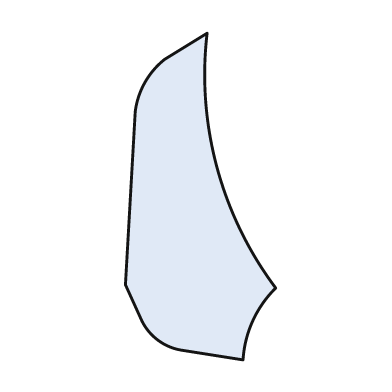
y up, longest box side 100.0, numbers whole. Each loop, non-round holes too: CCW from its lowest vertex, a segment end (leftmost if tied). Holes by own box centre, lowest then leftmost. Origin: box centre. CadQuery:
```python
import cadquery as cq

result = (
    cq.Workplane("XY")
    .moveTo(13.0, -50.0)
    .threePointArc((16.0, -38.0), (23.0, -28.0))
    .threePointArc((5.0, 9.0), (2.0, 50.0))
    .lineTo(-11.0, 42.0)
    .threePointArc((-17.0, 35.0), (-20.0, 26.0))
    .lineTo(-23.0, -27.0)
    .lineTo(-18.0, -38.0)
    .threePointArc((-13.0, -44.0), (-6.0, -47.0))
    .close()
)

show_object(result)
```